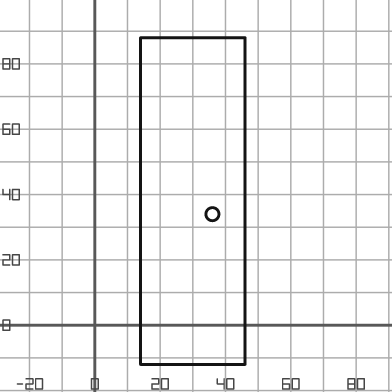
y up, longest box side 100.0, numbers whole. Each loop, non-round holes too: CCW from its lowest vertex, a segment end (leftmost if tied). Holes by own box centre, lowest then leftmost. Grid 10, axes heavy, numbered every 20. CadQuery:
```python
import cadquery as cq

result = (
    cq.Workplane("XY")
    .moveTo(14.0, -12.0)
    .lineTo(46.0, -12.0)
    .lineTo(46.0, 88.0)
    .lineTo(14.0, 88.0)
    .close()
    .moveTo(36.0, 34.0)
    .circle(2.0)
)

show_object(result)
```